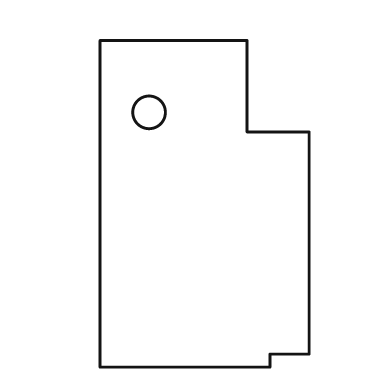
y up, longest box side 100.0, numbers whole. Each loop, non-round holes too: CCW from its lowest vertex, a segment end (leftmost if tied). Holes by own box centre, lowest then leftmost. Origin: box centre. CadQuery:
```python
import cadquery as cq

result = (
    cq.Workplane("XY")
    .moveTo(-32.0, -50.0)
    .lineTo(20.0, -50.0)
    .lineTo(20.0, -46.0)
    .lineTo(32.0, -46.0)
    .lineTo(32.0, 22.0)
    .lineTo(13.0, 22.0)
    .lineTo(13.0, 50.0)
    .lineTo(-32.0, 50.0)
    .close()
    .moveTo(-17.0, 28.0)
    .circle(5.0)
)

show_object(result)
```